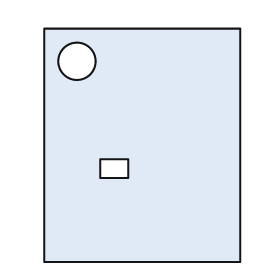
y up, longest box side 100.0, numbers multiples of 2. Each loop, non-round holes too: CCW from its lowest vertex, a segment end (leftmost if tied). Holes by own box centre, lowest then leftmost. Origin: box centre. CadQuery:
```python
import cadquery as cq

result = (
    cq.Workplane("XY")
    .moveTo(-42.0, -50.0)
    .lineTo(42.0, -50.0)
    .lineTo(42.0, 50.0)
    .lineTo(-42.0, 50.0)
    .close()
    .moveTo(-18.0, -14.0)
    .lineTo(-6.0, -14.0)
    .lineTo(-6.0, -6.0)
    .lineTo(-18.0, -6.0)
    .close()
    .moveTo(-28.0, 36.0)
    .circle(8.0)
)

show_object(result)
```